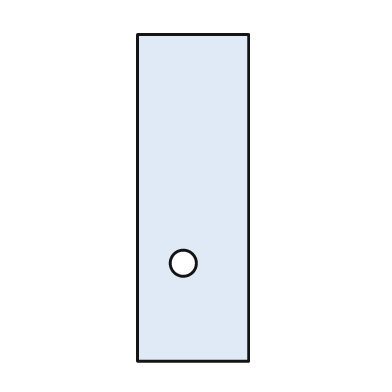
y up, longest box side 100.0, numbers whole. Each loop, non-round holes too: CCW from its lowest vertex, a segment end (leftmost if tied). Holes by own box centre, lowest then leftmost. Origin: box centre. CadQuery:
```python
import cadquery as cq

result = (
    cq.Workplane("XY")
    .moveTo(-17.0, -50.0)
    .lineTo(17.0, -50.0)
    .lineTo(17.0, 50.0)
    .lineTo(-17.0, 50.0)
    .close()
    .moveTo(-3.0, -20.0)
    .circle(4.0)
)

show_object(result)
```